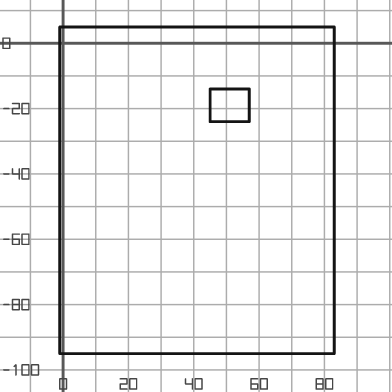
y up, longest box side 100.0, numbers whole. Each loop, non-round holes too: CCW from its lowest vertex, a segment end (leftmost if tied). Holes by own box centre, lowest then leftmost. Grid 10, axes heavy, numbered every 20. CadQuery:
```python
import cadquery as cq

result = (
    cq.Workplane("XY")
    .moveTo(-1.0, -95.0)
    .lineTo(83.0, -95.0)
    .lineTo(83.0, 5.0)
    .lineTo(-1.0, 5.0)
    .close()
    .moveTo(45.0, -24.0)
    .lineTo(57.0, -24.0)
    .lineTo(57.0, -14.0)
    .lineTo(45.0, -14.0)
    .close()
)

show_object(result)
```